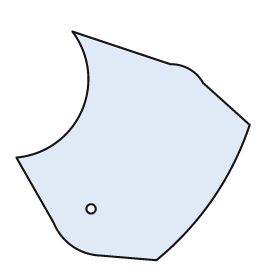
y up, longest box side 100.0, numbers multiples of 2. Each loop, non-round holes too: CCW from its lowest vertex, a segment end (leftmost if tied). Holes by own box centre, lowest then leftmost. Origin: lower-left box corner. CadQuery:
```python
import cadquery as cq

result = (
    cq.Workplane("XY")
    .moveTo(60.0, 0.0)
    .threePointArc((84.0, 26.0), (100.0, 58.0))
    .lineTo(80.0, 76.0)
    .threePointArc((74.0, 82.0), (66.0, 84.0))
    .lineTo(24.0, 98.0)
    .threePointArc((28.0, 64.0), (0.0, 44.0))
    .lineTo(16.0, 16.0)
    .threePointArc((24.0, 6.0), (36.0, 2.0))
    .close()
    .moveTo(32.0, 22.0)
    .circle(2.0)
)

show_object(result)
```